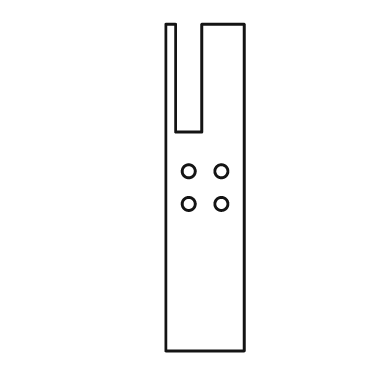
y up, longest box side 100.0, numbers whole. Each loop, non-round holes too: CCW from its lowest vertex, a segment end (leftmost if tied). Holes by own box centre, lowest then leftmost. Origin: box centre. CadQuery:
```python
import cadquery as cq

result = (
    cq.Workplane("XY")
    .moveTo(-12.0, -50.0)
    .lineTo(12.0, -50.0)
    .lineTo(12.0, 50.0)
    .lineTo(-1.0, 50.0)
    .lineTo(-1.0, 17.0)
    .lineTo(-9.0, 17.0)
    .lineTo(-9.0, 50.0)
    .lineTo(-12.0, 50.0)
    .close()
    .moveTo(-5.0, -5.0)
    .circle(2.0)
    .moveTo(5.0, -5.0)
    .circle(2.0)
    .moveTo(-5.0, 5.0)
    .circle(2.0)
    .moveTo(5.0, 5.0)
    .circle(2.0)
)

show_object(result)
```